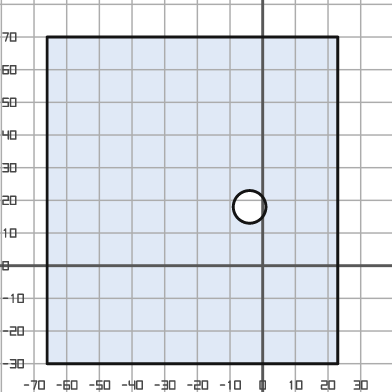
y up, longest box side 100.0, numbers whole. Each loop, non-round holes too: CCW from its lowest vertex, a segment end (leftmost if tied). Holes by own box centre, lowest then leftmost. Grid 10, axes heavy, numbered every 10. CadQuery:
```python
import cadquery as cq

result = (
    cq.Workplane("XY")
    .moveTo(-66.0, -30.0)
    .lineTo(23.0, -30.0)
    .lineTo(23.0, 70.0)
    .lineTo(-66.0, 70.0)
    .close()
    .moveTo(-4.0, 18.0)
    .circle(5.0)
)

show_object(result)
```